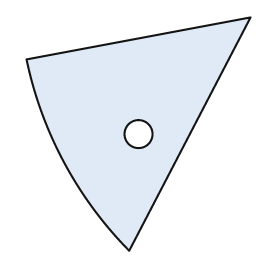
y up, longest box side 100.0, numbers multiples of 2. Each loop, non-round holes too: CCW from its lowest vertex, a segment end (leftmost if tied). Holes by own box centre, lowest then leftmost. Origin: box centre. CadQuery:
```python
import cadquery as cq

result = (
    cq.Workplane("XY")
    .moveTo(-4.0, -50.0)
    .lineTo(48.0, 50.0)
    .lineTo(-48.0, 32.0)
    .threePointArc((-32.0, -12.0), (-4.0, -50.0))
    .close()
    .moveTo(0.0, 0.0)
    .circle(6.0)
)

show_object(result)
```